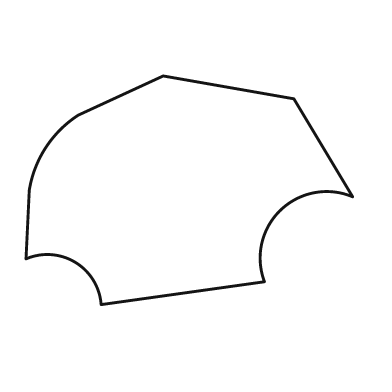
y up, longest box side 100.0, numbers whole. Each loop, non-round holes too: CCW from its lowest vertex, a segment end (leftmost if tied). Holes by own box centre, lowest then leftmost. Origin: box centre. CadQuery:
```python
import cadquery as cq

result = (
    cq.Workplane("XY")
    .moveTo(-27.0, -35.0)
    .lineTo(23.0, -28.0)
    .threePointArc((28.0, -6.0), (50.0, -2.0))
    .lineTo(32.0, 28.0)
    .lineTo(-8.0, 35.0)
    .lineTo(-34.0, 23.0)
    .threePointArc((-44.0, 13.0), (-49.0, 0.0))
    .lineTo(-50.0, -21.0)
    .threePointArc((-35.0, -22.0), (-27.0, -35.0))
    .close()
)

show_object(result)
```